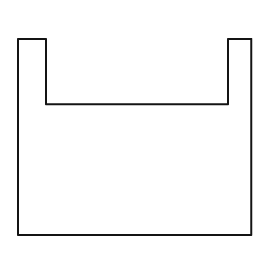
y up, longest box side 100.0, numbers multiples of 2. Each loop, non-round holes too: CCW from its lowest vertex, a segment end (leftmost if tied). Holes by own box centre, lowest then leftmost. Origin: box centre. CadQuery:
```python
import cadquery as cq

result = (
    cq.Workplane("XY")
    .moveTo(-50.0, -42.0)
    .lineTo(50.0, -42.0)
    .lineTo(50.0, 42.0)
    .lineTo(40.0, 42.0)
    .lineTo(40.0, 14.0)
    .lineTo(-38.0, 14.0)
    .lineTo(-38.0, 42.0)
    .lineTo(-50.0, 42.0)
    .close()
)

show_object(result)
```